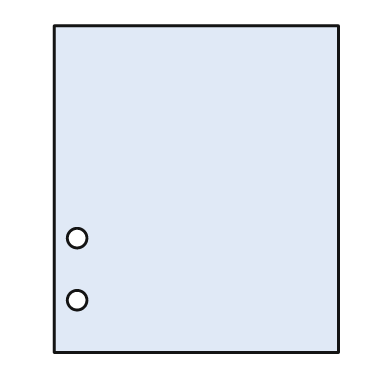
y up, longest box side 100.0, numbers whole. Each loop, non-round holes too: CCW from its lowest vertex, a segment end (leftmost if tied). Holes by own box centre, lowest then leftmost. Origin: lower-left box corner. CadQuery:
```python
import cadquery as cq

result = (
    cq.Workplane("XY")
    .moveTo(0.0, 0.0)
    .lineTo(87.0, 0.0)
    .lineTo(87.0, 100.0)
    .lineTo(0.0, 100.0)
    .close()
    .moveTo(7.0, 16.0)
    .circle(3.0)
    .moveTo(7.0, 35.0)
    .circle(3.0)
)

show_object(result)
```